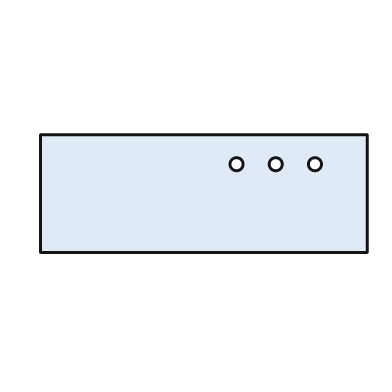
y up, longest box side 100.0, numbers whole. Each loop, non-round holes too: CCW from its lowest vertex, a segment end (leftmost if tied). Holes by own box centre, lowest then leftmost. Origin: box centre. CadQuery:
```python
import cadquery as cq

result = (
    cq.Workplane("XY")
    .moveTo(-50.0, -18.0)
    .lineTo(50.0, -18.0)
    .lineTo(50.0, 18.0)
    .lineTo(-50.0, 18.0)
    .close()
    .moveTo(10.0, 9.0)
    .circle(2.0)
    .moveTo(22.0, 9.0)
    .circle(2.0)
    .moveTo(34.0, 9.0)
    .circle(2.0)
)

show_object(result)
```